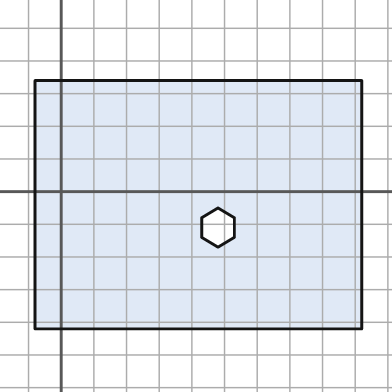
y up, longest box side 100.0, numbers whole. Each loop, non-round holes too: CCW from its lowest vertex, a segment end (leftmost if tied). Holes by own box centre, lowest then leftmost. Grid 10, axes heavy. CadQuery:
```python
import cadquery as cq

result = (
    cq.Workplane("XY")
    .moveTo(-8.0, -42.0)
    .lineTo(92.0, -42.0)
    .lineTo(92.0, 34.0)
    .lineTo(-8.0, 34.0)
    .close()
    .moveTo(48.0, -17.0)
    .lineTo(53.0, -14.0)
    .lineTo(53.0, -8.0)
    .lineTo(48.0, -5.0)
    .lineTo(43.0, -8.0)
    .lineTo(43.0, -14.0)
    .close()
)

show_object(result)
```